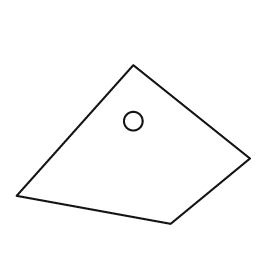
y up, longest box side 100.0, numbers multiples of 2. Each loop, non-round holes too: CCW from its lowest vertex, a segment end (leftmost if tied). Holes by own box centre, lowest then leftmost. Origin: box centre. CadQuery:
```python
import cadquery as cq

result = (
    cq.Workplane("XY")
    .moveTo(16.0, -34.0)
    .lineTo(50.0, -6.0)
    .lineTo(0.0, 34.0)
    .lineTo(-50.0, -22.0)
    .close()
    .moveTo(0.0, 10.0)
    .circle(4.0)
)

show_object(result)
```